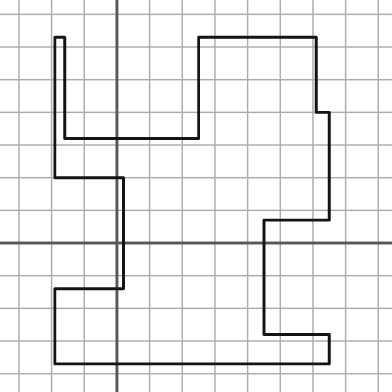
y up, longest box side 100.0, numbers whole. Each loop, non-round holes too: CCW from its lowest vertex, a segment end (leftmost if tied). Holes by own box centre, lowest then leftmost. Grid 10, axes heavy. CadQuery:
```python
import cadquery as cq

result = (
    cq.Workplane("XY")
    .moveTo(-19.0, -37.0)
    .lineTo(65.0, -37.0)
    .lineTo(65.0, -28.0)
    .lineTo(45.0, -28.0)
    .lineTo(45.0, 7.0)
    .lineTo(65.0, 7.0)
    .lineTo(65.0, 40.0)
    .lineTo(61.0, 40.0)
    .lineTo(61.0, 63.0)
    .lineTo(25.0, 63.0)
    .lineTo(25.0, 32.0)
    .lineTo(-16.0, 32.0)
    .lineTo(-16.0, 63.0)
    .lineTo(-19.0, 63.0)
    .lineTo(-19.0, 20.0)
    .lineTo(2.0, 20.0)
    .lineTo(2.0, -14.0)
    .lineTo(-19.0, -14.0)
    .close()
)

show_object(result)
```